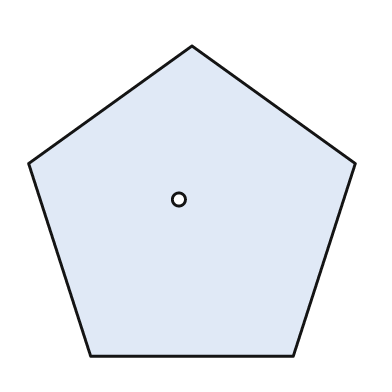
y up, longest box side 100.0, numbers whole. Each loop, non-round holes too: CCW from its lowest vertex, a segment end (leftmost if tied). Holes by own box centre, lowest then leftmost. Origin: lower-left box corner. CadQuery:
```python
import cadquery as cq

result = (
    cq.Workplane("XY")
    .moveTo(19.0, 0.0)
    .lineTo(81.0, 0.0)
    .lineTo(100.0, 59.0)
    .lineTo(50.0, 95.0)
    .lineTo(0.0, 59.0)
    .close()
    .moveTo(46.0, 48.0)
    .circle(2.0)
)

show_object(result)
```